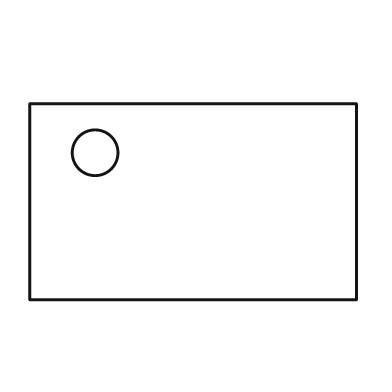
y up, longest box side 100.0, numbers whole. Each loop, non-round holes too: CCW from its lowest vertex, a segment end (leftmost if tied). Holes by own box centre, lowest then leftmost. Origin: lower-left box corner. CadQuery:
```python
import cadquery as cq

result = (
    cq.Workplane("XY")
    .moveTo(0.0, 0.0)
    .lineTo(100.0, 0.0)
    .lineTo(100.0, 60.0)
    .lineTo(0.0, 60.0)
    .close()
    .moveTo(20.0, 45.0)
    .circle(7.0)
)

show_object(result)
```